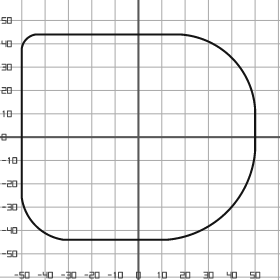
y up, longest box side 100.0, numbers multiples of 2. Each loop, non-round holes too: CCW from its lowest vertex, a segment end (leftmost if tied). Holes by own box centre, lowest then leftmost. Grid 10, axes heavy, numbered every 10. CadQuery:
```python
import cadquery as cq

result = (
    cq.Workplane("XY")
    .moveTo(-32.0, -44.0)
    .lineTo(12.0, -44.0)
    .threePointArc((38.0, -32.0), (50.0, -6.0))
    .lineTo(50.0, 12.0)
    .threePointArc((40.0, 34.0), (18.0, 44.0))
    .lineTo(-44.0, 44.0)
    .threePointArc((-48.0, 42.0), (-50.0, 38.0))
    .lineTo(-50.0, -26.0)
    .threePointArc((-44.0, -38.0), (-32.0, -44.0))
    .close()
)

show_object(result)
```